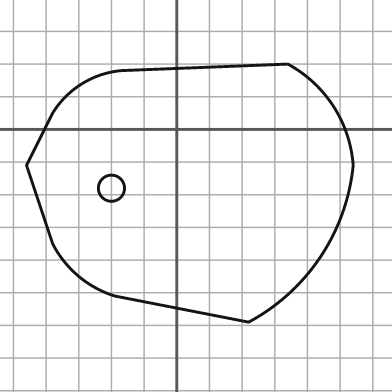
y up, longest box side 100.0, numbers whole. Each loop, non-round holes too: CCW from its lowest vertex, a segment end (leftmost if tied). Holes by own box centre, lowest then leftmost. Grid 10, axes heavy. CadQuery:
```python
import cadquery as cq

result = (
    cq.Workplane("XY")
    .moveTo(22.0, -59.0)
    .threePointArc((44.0, -39.0), (54.0, -11.0))
    .threePointArc((48.0, 7.0), (34.0, 20.0))
    .lineTo(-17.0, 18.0)
    .threePointArc((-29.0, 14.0), (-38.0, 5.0))
    .lineTo(-46.0, -11.0)
    .lineTo(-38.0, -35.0)
    .threePointArc((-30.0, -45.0), (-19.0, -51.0))
    .close()
    .moveTo(-20.0, -18.0)
    .circle(4.0)
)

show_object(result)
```